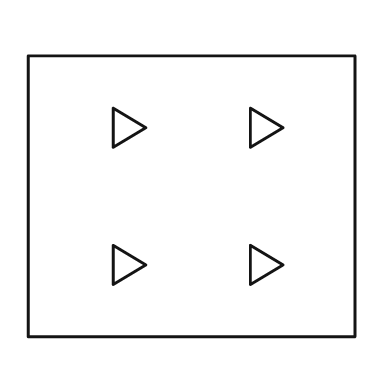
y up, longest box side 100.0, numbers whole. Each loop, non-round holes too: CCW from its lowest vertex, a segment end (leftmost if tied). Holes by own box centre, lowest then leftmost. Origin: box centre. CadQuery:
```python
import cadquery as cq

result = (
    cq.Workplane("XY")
    .moveTo(-50.0, -43.0)
    .lineTo(50.0, -43.0)
    .lineTo(50.0, 43.0)
    .lineTo(-50.0, 43.0)
    .close()
    .moveTo(-24.0, -27.0)
    .lineTo(-14.0, -21.0)
    .lineTo(-24.0, -15.0)
    .close()
    .moveTo(18.0, -27.0)
    .lineTo(28.0, -21.0)
    .lineTo(18.0, -15.0)
    .close()
    .moveTo(-24.0, 15.0)
    .lineTo(-14.0, 21.0)
    .lineTo(-24.0, 27.0)
    .close()
    .moveTo(18.0, 15.0)
    .lineTo(28.0, 21.0)
    .lineTo(18.0, 27.0)
    .close()
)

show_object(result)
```